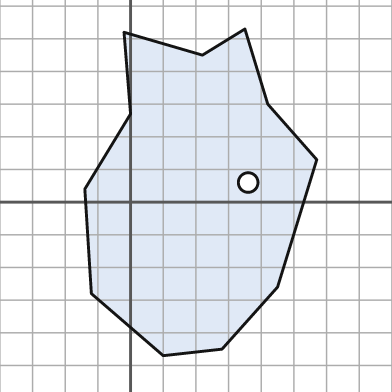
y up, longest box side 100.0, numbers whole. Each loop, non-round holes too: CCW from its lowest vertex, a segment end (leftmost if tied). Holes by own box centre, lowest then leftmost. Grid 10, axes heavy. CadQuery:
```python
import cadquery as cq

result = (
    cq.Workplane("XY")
    .moveTo(10.0, -47.0)
    .lineTo(28.0, -45.0)
    .lineTo(45.0, -26.0)
    .lineTo(57.0, 13.0)
    .lineTo(42.0, 30.0)
    .lineTo(35.0, 53.0)
    .lineTo(22.0, 45.0)
    .lineTo(-2.0, 52.0)
    .lineTo(0.0, 27.0)
    .lineTo(-14.0, 4.0)
    .lineTo(-12.0, -28.0)
    .close()
    .moveTo(36.0, 6.0)
    .circle(3.0)
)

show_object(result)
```